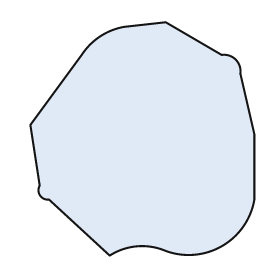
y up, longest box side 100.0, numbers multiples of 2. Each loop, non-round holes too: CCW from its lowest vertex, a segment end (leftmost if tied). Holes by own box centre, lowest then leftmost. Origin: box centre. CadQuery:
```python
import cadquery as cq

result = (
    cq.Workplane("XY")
    .moveTo(-14.0, -50.0)
    .threePointArc((-2.0, -46.0), (10.0, -48.0))
    .threePointArc((34.0, -46.0), (48.0, -26.0))
    .lineTo(48.0, 2.0)
    .lineTo(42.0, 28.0)
    .threePointArc((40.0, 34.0), (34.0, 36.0))
    .lineTo(10.0, 50.0)
    .lineTo(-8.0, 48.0)
    .threePointArc((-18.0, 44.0), (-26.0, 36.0))
    .lineTo(-48.0, 6.0)
    .lineTo(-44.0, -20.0)
    .threePointArc((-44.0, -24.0), (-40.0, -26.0))
    .close()
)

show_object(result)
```